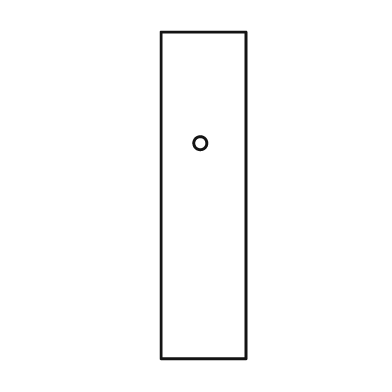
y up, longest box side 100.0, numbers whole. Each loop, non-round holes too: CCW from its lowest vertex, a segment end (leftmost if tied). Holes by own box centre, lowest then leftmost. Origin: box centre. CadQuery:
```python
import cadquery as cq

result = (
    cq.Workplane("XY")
    .moveTo(-13.0, -50.0)
    .lineTo(13.0, -50.0)
    .lineTo(13.0, 50.0)
    .lineTo(-13.0, 50.0)
    .close()
    .moveTo(-1.0, 16.0)
    .circle(2.0)
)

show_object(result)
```